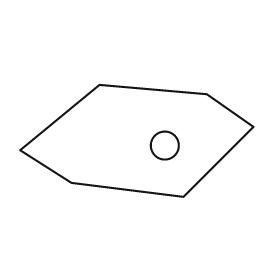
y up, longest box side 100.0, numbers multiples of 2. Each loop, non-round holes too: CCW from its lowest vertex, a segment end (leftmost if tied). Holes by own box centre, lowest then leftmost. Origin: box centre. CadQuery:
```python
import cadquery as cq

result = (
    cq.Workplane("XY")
    .moveTo(20.0, -24.0)
    .lineTo(50.0, 6.0)
    .lineTo(30.0, 20.0)
    .lineTo(-16.0, 24.0)
    .lineTo(-50.0, -4.0)
    .lineTo(-28.0, -18.0)
    .close()
    .moveTo(12.0, -2.0)
    .circle(6.0)
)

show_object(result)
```